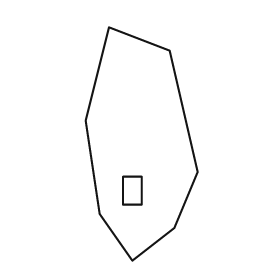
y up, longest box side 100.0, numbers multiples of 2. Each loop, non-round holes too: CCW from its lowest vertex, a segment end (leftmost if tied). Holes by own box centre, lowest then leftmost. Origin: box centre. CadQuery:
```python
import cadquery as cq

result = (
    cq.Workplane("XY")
    .moveTo(-4.0, -50.0)
    .lineTo(14.0, -36.0)
    .lineTo(24.0, -12.0)
    .lineTo(12.0, 40.0)
    .lineTo(-14.0, 50.0)
    .lineTo(-24.0, 10.0)
    .lineTo(-18.0, -30.0)
    .close()
    .moveTo(-8.0, -26.0)
    .lineTo(0.0, -26.0)
    .lineTo(0.0, -14.0)
    .lineTo(-8.0, -14.0)
    .close()
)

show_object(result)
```